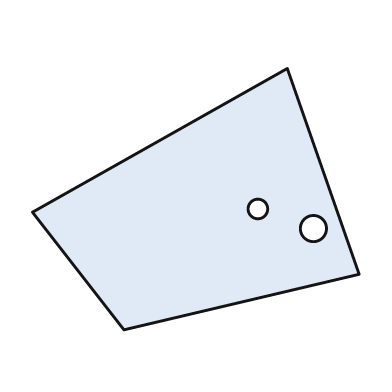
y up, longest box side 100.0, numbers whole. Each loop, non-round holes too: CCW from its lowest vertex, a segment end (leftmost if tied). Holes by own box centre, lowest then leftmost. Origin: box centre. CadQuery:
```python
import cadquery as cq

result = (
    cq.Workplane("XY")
    .moveTo(-22.0, -40.0)
    .lineTo(50.0, -23.0)
    .lineTo(28.0, 40.0)
    .lineTo(-50.0, -4.0)
    .close()
    .moveTo(36.0, -9.0)
    .circle(4.0)
    .moveTo(19.0, -3.0)
    .circle(3.0)
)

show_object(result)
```